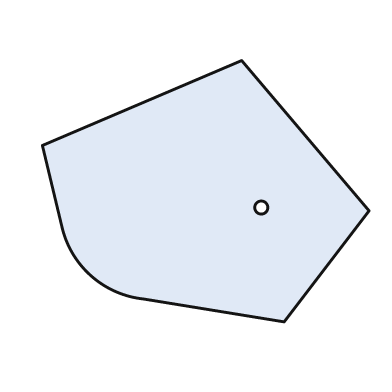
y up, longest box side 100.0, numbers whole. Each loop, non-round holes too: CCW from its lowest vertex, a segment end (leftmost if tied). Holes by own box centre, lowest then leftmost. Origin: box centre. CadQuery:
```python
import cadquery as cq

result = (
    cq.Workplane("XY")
    .moveTo(24.0, -40.0)
    .lineTo(50.0, -6.0)
    .lineTo(11.0, 40.0)
    .lineTo(-50.0, 14.0)
    .lineTo(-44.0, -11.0)
    .threePointArc((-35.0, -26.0), (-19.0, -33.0))
    .close()
    .moveTo(17.0, -5.0)
    .circle(2.0)
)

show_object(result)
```